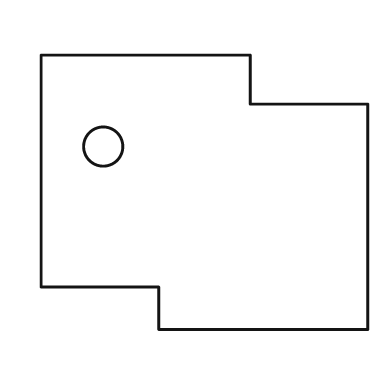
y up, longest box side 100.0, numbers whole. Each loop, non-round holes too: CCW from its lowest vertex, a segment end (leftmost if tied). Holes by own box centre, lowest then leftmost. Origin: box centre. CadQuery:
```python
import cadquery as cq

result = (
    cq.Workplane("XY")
    .moveTo(-14.0, -42.0)
    .lineTo(50.0, -42.0)
    .lineTo(50.0, 27.0)
    .lineTo(14.0, 27.0)
    .lineTo(14.0, 42.0)
    .lineTo(-50.0, 42.0)
    .lineTo(-50.0, -29.0)
    .lineTo(-14.0, -29.0)
    .close()
    .moveTo(-31.0, 14.0)
    .circle(6.0)
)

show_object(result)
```